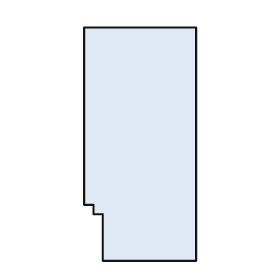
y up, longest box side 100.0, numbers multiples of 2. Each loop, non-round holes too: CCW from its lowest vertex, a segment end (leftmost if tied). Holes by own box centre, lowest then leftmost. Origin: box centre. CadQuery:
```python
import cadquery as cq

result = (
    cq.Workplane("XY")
    .moveTo(-16.0, -50.0)
    .lineTo(24.0, -50.0)
    .lineTo(24.0, 50.0)
    .lineTo(-24.0, 50.0)
    .lineTo(-24.0, -26.0)
    .lineTo(-20.0, -26.0)
    .lineTo(-20.0, -30.0)
    .lineTo(-16.0, -30.0)
    .close()
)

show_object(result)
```